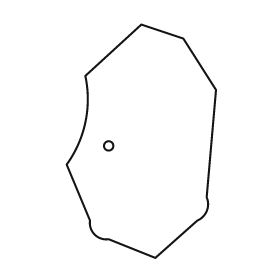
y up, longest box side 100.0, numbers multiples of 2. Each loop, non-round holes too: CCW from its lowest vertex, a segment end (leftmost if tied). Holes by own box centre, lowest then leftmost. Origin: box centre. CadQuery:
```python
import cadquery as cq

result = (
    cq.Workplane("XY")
    .moveTo(6.0, -50.0)
    .lineTo(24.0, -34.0)
    .threePointArc((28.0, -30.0), (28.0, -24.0))
    .lineTo(32.0, 22.0)
    .lineTo(18.0, 44.0)
    .lineTo(0.0, 50.0)
    .lineTo(-24.0, 28.0)
    .threePointArc((-24.0, 8.0), (-32.0, -10.0))
    .lineTo(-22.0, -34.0)
    .threePointArc((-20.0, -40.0), (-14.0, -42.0))
    .close()
    .moveTo(-14.0, -2.0)
    .circle(2.0)
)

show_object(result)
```